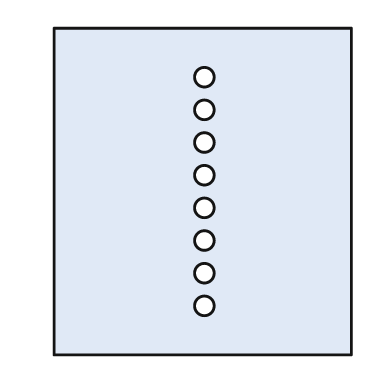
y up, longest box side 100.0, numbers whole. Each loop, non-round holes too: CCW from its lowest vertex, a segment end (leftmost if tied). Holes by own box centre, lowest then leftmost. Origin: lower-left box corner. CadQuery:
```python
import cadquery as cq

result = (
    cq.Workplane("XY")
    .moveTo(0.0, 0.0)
    .lineTo(91.0, 0.0)
    .lineTo(91.0, 100.0)
    .lineTo(0.0, 100.0)
    .close()
    .moveTo(46.0, 15.0)
    .circle(3.0)
    .moveTo(46.0, 25.0)
    .circle(3.0)
    .moveTo(46.0, 35.0)
    .circle(3.0)
    .moveTo(46.0, 45.0)
    .circle(3.0)
    .moveTo(46.0, 55.0)
    .circle(3.0)
    .moveTo(46.0, 65.0)
    .circle(3.0)
    .moveTo(46.0, 75.0)
    .circle(3.0)
    .moveTo(46.0, 85.0)
    .circle(3.0)
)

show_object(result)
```